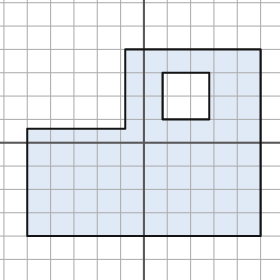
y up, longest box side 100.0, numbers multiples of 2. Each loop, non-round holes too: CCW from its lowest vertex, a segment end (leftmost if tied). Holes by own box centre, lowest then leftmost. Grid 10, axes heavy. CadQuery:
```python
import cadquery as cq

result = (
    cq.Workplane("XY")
    .moveTo(-50.0, -40.0)
    .lineTo(50.0, -40.0)
    .lineTo(50.0, 40.0)
    .lineTo(-8.0, 40.0)
    .lineTo(-8.0, 6.0)
    .lineTo(-50.0, 6.0)
    .close()
    .moveTo(8.0, 10.0)
    .lineTo(28.0, 10.0)
    .lineTo(28.0, 30.0)
    .lineTo(8.0, 30.0)
    .close()
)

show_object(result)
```